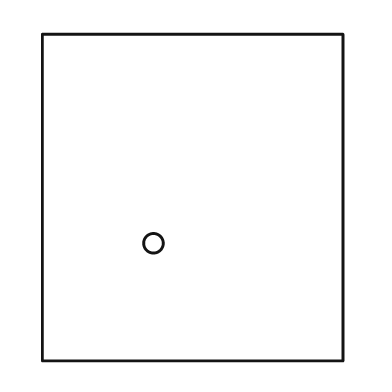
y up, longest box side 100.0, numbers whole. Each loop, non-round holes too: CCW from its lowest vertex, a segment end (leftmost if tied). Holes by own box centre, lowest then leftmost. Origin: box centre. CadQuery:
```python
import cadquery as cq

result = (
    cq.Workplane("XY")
    .moveTo(-46.0, -50.0)
    .lineTo(46.0, -50.0)
    .lineTo(46.0, 50.0)
    .lineTo(-46.0, 50.0)
    .close()
    .moveTo(-12.0, -14.0)
    .circle(3.0)
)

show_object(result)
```